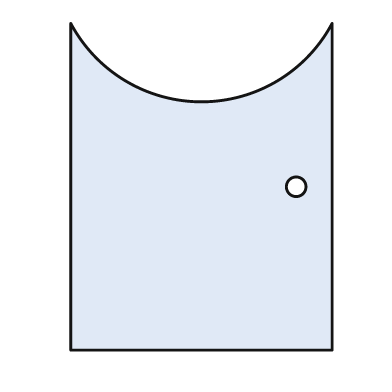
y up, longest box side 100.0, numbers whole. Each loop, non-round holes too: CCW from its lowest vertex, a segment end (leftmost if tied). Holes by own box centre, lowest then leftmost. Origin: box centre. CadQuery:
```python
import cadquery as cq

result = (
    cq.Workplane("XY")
    .moveTo(-40.0, -50.0)
    .lineTo(40.0, -50.0)
    .lineTo(40.0, 50.0)
    .threePointArc((0.0, 26.0), (-40.0, 50.0))
    .close()
    .moveTo(29.0, 0.0)
    .circle(3.0)
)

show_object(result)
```